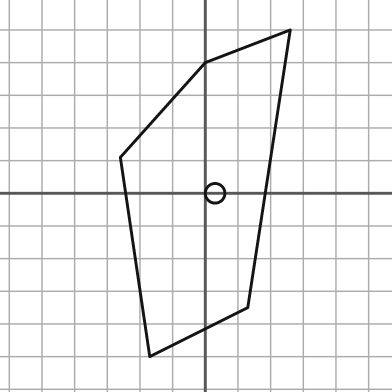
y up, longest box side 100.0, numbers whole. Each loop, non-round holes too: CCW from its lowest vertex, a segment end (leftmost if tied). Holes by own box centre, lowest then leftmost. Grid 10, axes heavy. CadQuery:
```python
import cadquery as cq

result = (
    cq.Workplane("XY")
    .moveTo(-17.0, -50.0)
    .lineTo(13.0, -35.0)
    .lineTo(26.0, 50.0)
    .lineTo(0.0, 40.0)
    .lineTo(-26.0, 11.0)
    .close()
    .moveTo(3.0, 0.0)
    .circle(3.0)
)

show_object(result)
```